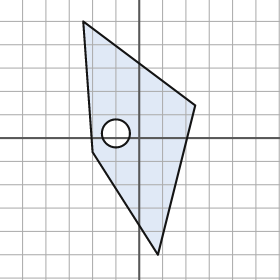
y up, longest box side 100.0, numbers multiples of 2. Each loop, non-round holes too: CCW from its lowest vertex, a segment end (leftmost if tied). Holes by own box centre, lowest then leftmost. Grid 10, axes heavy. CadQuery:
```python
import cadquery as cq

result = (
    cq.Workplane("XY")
    .moveTo(8.0, -50.0)
    .lineTo(24.0, 14.0)
    .lineTo(-24.0, 50.0)
    .lineTo(-20.0, -6.0)
    .close()
    .moveTo(-10.0, 2.0)
    .circle(6.0)
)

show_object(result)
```